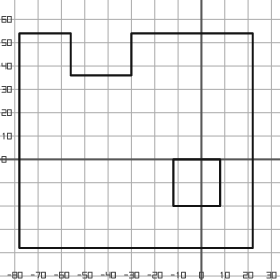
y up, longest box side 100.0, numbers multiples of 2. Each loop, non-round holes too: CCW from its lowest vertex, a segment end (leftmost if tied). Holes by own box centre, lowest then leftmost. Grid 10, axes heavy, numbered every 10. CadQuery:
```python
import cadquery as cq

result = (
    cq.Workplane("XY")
    .moveTo(-78.0, -38.0)
    .lineTo(22.0, -38.0)
    .lineTo(22.0, 54.0)
    .lineTo(-30.0, 54.0)
    .lineTo(-30.0, 36.0)
    .lineTo(-56.0, 36.0)
    .lineTo(-56.0, 54.0)
    .lineTo(-78.0, 54.0)
    .close()
    .moveTo(-12.0, -20.0)
    .lineTo(8.0, -20.0)
    .lineTo(8.0, 0.0)
    .lineTo(-12.0, 0.0)
    .close()
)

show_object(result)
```